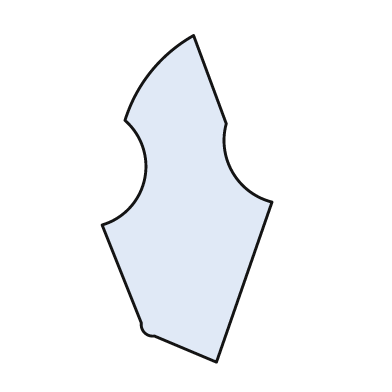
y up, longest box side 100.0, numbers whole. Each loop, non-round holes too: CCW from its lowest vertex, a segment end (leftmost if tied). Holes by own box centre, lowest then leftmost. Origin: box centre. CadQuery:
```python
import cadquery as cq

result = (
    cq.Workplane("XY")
    .moveTo(9.0, -50.0)
    .lineTo(26.0, -1.0)
    .threePointArc((14.0, 8.0), (12.0, 23.0))
    .lineTo(2.0, 50.0)
    .threePointArc((-11.0, 39.0), (-19.0, 24.0))
    .threePointArc((-13.0, 6.0), (-26.0, -8.0))
    .lineTo(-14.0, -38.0)
    .threePointArc((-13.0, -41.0), (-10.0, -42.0))
    .close()
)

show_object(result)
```